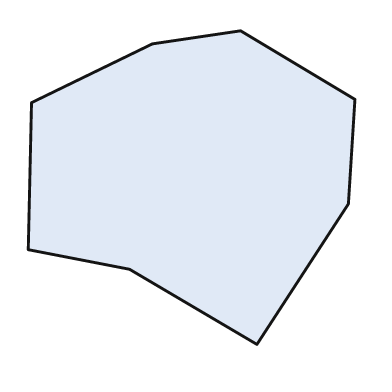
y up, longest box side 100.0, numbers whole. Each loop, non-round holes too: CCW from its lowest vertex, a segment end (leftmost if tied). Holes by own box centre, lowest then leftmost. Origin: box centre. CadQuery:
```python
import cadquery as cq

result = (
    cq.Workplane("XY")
    .moveTo(20.0, -48.0)
    .lineTo(48.0, -5.0)
    .lineTo(50.0, 27.0)
    .lineTo(15.0, 48.0)
    .lineTo(-12.0, 44.0)
    .lineTo(-49.0, 26.0)
    .lineTo(-50.0, -19.0)
    .lineTo(-19.0, -25.0)
    .close()
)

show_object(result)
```